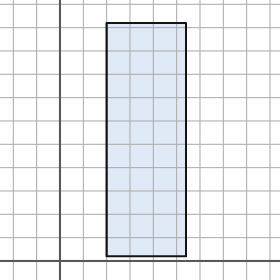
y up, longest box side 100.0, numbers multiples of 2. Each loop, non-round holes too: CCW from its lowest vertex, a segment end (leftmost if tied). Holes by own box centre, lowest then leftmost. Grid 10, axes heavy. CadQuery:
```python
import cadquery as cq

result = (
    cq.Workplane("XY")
    .moveTo(20.0, 2.0)
    .lineTo(54.0, 2.0)
    .lineTo(54.0, 102.0)
    .lineTo(20.0, 102.0)
    .close()
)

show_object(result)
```